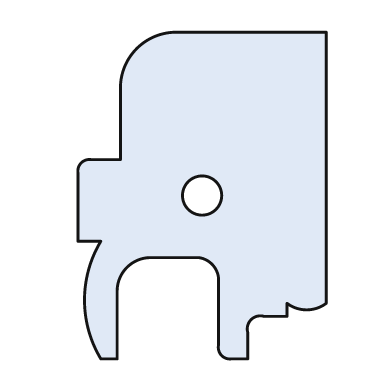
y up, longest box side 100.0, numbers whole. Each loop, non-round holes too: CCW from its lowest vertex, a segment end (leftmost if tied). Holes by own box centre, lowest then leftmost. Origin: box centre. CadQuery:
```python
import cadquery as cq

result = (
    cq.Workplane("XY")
    .moveTo(-31.0, -50.0)
    .lineTo(-26.0, -50.0)
    .lineTo(-26.0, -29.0)
    .threePointArc((-23.0, -22.0), (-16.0, -19.0))
    .lineTo(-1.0, -19.0)
    .threePointArc((3.0, -21.0), (5.0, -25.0))
    .lineTo(5.0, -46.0)
    .threePointArc((6.0, -49.0), (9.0, -50.0))
    .lineTo(14.0, -50.0)
    .lineTo(14.0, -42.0)
    .threePointArc((15.0, -38.0), (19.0, -37.0))
    .lineTo(26.0, -37.0)
    .lineTo(26.0, -33.0)
    .threePointArc((32.0, -35.0), (38.0, -33.0))
    .lineTo(38.0, 50.0)
    .lineTo(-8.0, 50.0)
    .threePointArc((-20.0, 45.0), (-25.0, 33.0))
    .lineTo(-25.0, 11.0)
    .lineTo(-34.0, 11.0)
    .threePointArc((-37.0, 10.0), (-38.0, 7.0))
    .lineTo(-38.0, -14.0)
    .lineTo(-31.0, -14.0)
    .threePointArc((-36.0, -32.0), (-31.0, -50.0))
    .close()
    .moveTo(0.0, 0.0)
    .circle(6.0)
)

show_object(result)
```